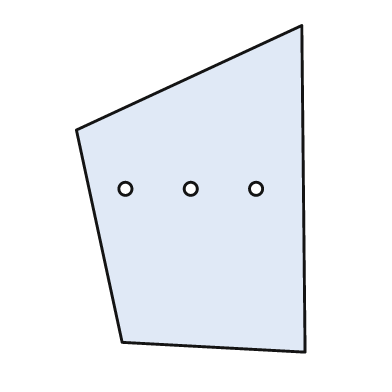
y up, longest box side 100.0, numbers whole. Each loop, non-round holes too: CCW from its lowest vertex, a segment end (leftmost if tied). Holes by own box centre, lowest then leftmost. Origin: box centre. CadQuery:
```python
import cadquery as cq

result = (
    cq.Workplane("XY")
    .moveTo(35.0, -50.0)
    .lineTo(34.0, 50.0)
    .lineTo(-35.0, 18.0)
    .lineTo(-21.0, -47.0)
    .close()
    .moveTo(-20.0, 0.0)
    .circle(2.0)
    .moveTo(0.0, 0.0)
    .circle(2.0)
    .moveTo(20.0, 0.0)
    .circle(2.0)
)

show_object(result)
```